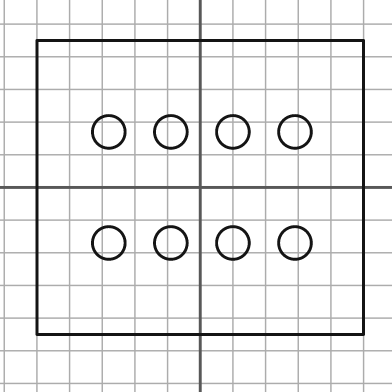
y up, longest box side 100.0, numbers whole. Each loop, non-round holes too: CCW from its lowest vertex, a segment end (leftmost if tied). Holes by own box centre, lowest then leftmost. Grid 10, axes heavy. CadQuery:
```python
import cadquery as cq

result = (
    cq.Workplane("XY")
    .moveTo(-50.0, -45.0)
    .lineTo(50.0, -45.0)
    .lineTo(50.0, 45.0)
    .lineTo(-50.0, 45.0)
    .close()
    .moveTo(-28.0, -17.0)
    .circle(5.0)
    .moveTo(-9.0, -17.0)
    .circle(5.0)
    .moveTo(10.0, -17.0)
    .circle(5.0)
    .moveTo(29.0, -17.0)
    .circle(5.0)
    .moveTo(-28.0, 17.0)
    .circle(5.0)
    .moveTo(-9.0, 17.0)
    .circle(5.0)
    .moveTo(10.0, 17.0)
    .circle(5.0)
    .moveTo(29.0, 17.0)
    .circle(5.0)
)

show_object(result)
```